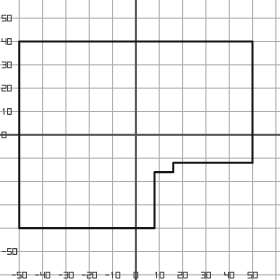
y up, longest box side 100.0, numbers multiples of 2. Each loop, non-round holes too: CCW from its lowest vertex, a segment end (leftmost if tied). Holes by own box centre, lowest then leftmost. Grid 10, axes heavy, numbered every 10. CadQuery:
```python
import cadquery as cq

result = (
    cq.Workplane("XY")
    .moveTo(-50.0, -40.0)
    .lineTo(8.0, -40.0)
    .lineTo(8.0, -16.0)
    .lineTo(16.0, -16.0)
    .lineTo(16.0, -12.0)
    .lineTo(50.0, -12.0)
    .lineTo(50.0, 40.0)
    .lineTo(-50.0, 40.0)
    .close()
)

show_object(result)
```